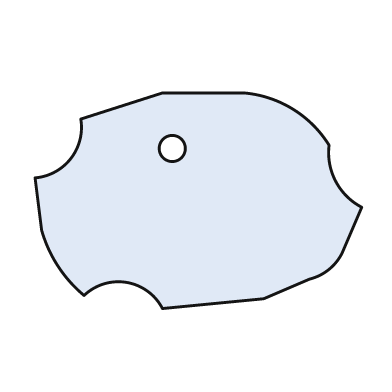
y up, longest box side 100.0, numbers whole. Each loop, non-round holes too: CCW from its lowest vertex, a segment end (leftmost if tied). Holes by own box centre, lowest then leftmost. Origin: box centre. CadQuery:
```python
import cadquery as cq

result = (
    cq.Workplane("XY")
    .moveTo(-11.0, -33.0)
    .lineTo(20.0, -30.0)
    .lineTo(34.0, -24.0)
    .threePointArc((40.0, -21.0), (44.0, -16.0))
    .lineTo(50.0, -2.0)
    .threePointArc((42.0, 6.0), (40.0, 17.0))
    .threePointArc((29.0, 28.0), (14.0, 33.0))
    .lineTo(-11.0, 33.0)
    .lineTo(-36.0, 25.0)
    .threePointArc((-39.0, 13.0), (-50.0, 7.0))
    .lineTo(-48.0, -9.0)
    .threePointArc((-43.0, -20.0), (-35.0, -29.0))
    .threePointArc((-22.0, -25.0), (-11.0, -33.0))
    .close()
    .moveTo(-8.0, 16.0)
    .circle(4.0)
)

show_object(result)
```